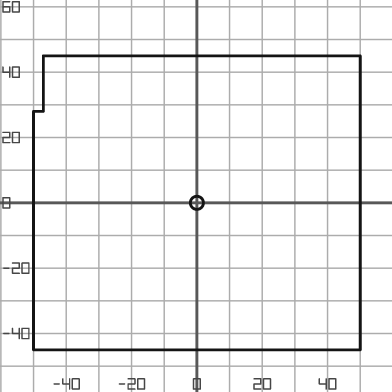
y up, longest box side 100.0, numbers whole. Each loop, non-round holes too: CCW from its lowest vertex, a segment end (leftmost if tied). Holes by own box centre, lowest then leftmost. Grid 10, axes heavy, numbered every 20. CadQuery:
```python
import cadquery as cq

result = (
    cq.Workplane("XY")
    .moveTo(-50.0, -45.0)
    .lineTo(50.0, -45.0)
    .lineTo(50.0, 45.0)
    .lineTo(-47.0, 45.0)
    .lineTo(-47.0, 28.0)
    .lineTo(-50.0, 28.0)
    .close()
    .moveTo(0.0, 0.0)
    .circle(2.0)
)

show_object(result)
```